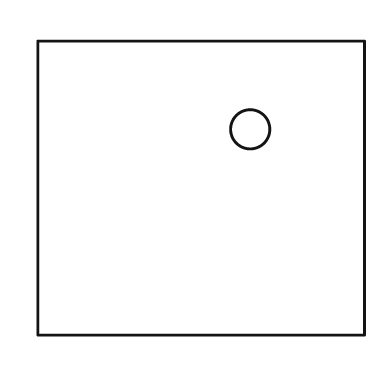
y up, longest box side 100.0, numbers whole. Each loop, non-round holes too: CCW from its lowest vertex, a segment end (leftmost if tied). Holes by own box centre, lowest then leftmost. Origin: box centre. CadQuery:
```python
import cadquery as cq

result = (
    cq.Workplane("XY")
    .moveTo(-50.0, -45.0)
    .lineTo(50.0, -45.0)
    .lineTo(50.0, 45.0)
    .lineTo(-50.0, 45.0)
    .close()
    .moveTo(15.0, 18.0)
    .circle(6.0)
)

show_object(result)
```